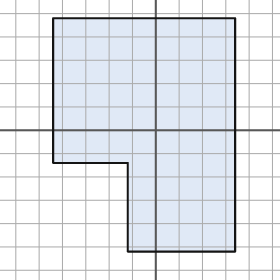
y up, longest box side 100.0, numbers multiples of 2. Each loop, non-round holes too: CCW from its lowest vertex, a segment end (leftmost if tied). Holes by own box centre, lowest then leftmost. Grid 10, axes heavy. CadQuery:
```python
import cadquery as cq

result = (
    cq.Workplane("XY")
    .moveTo(-12.0, -52.0)
    .lineTo(34.0, -52.0)
    .lineTo(34.0, 48.0)
    .lineTo(-44.0, 48.0)
    .lineTo(-44.0, -14.0)
    .lineTo(-12.0, -14.0)
    .close()
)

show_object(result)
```